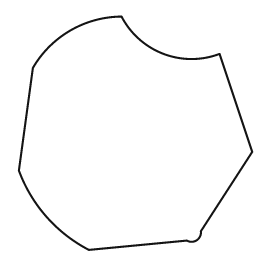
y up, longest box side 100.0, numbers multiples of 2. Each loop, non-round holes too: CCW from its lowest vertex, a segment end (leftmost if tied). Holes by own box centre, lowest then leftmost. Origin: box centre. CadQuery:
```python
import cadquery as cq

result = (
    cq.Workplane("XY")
    .moveTo(-20.0, -50.0)
    .lineTo(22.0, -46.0)
    .threePointArc((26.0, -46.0), (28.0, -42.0))
    .lineTo(50.0, -8.0)
    .lineTo(36.0, 34.0)
    .threePointArc((12.0, 34.0), (-6.0, 50.0))
    .threePointArc((-28.0, 44.0), (-44.0, 28.0))
    .lineTo(-50.0, -16.0)
    .threePointArc((-38.0, -36.0), (-20.0, -50.0))
    .close()
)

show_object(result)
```